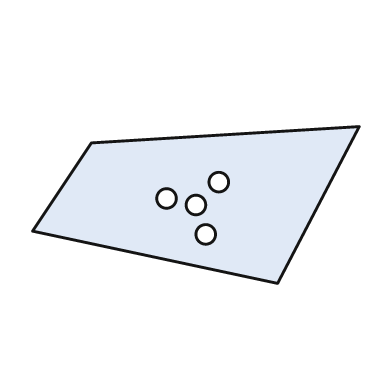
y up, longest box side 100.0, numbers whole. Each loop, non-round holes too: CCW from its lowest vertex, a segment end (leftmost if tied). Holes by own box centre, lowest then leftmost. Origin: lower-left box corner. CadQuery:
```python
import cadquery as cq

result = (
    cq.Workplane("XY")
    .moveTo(75.0, 0.0)
    .lineTo(100.0, 48.0)
    .lineTo(18.0, 43.0)
    .lineTo(0.0, 16.0)
    .close()
    .moveTo(53.0, 15.0)
    .circle(3.0)
    .moveTo(50.0, 24.0)
    .circle(3.0)
    .moveTo(41.0, 26.0)
    .circle(3.0)
    .moveTo(57.0, 31.0)
    .circle(3.0)
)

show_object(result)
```